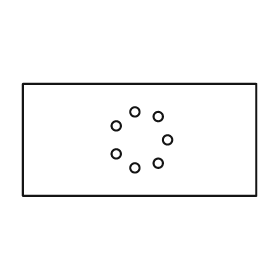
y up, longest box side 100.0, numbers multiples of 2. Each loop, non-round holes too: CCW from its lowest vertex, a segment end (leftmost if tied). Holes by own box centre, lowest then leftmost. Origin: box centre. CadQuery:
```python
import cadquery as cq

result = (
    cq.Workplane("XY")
    .moveTo(-50.0, -24.0)
    .lineTo(50.0, -24.0)
    .lineTo(50.0, 24.0)
    .lineTo(-50.0, 24.0)
    .close()
    .moveTo(-2.0, -12.0)
    .circle(2.0)
    .moveTo(8.0, -10.0)
    .circle(2.0)
    .moveTo(-10.0, -6.0)
    .circle(2.0)
    .moveTo(12.0, 0.0)
    .circle(2.0)
    .moveTo(-10.0, 6.0)
    .circle(2.0)
    .moveTo(8.0, 10.0)
    .circle(2.0)
    .moveTo(-2.0, 12.0)
    .circle(2.0)
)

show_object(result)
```